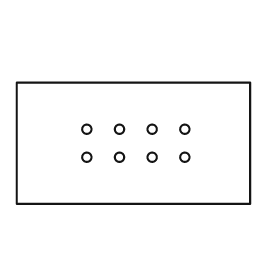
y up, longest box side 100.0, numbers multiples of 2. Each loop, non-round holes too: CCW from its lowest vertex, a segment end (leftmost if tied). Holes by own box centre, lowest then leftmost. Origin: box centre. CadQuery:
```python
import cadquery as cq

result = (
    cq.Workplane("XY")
    .moveTo(-50.0, -26.0)
    .lineTo(50.0, -26.0)
    .lineTo(50.0, 26.0)
    .lineTo(-50.0, 26.0)
    .close()
    .moveTo(-20.0, -6.0)
    .circle(2.0)
    .moveTo(-6.0, -6.0)
    .circle(2.0)
    .moveTo(8.0, -6.0)
    .circle(2.0)
    .moveTo(22.0, -6.0)
    .circle(2.0)
    .moveTo(-20.0, 6.0)
    .circle(2.0)
    .moveTo(-6.0, 6.0)
    .circle(2.0)
    .moveTo(8.0, 6.0)
    .circle(2.0)
    .moveTo(22.0, 6.0)
    .circle(2.0)
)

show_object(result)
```